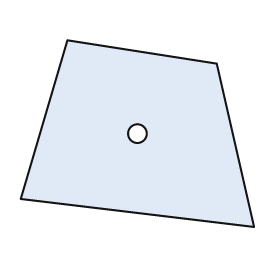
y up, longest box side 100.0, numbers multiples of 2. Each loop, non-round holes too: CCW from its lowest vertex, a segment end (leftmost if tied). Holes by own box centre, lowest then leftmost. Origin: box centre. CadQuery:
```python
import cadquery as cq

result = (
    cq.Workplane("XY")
    .moveTo(50.0, -40.0)
    .lineTo(34.0, 30.0)
    .lineTo(-30.0, 40.0)
    .lineTo(-50.0, -28.0)
    .close()
    .moveTo(0.0, 0.0)
    .circle(4.0)
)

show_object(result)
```